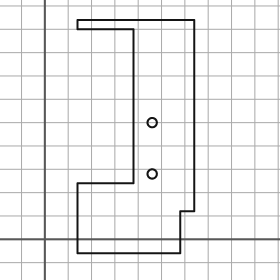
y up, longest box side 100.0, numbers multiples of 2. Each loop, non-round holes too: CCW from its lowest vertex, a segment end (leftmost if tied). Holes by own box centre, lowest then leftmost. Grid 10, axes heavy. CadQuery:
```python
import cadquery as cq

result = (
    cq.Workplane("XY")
    .moveTo(14.0, -6.0)
    .lineTo(58.0, -6.0)
    .lineTo(58.0, 12.0)
    .lineTo(64.0, 12.0)
    .lineTo(64.0, 94.0)
    .lineTo(14.0, 94.0)
    .lineTo(14.0, 90.0)
    .lineTo(38.0, 90.0)
    .lineTo(38.0, 24.0)
    .lineTo(14.0, 24.0)
    .close()
    .moveTo(46.0, 28.0)
    .circle(2.0)
    .moveTo(46.0, 50.0)
    .circle(2.0)
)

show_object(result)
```